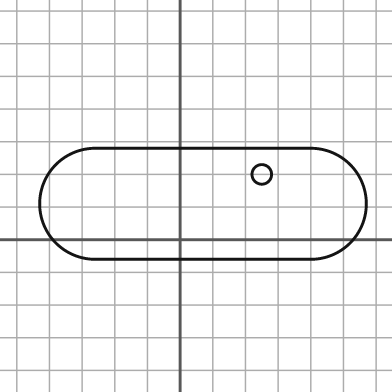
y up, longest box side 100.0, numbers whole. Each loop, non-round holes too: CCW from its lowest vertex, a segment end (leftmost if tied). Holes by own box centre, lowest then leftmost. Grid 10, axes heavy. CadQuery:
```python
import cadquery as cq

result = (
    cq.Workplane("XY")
    .moveTo(-26.0, -6.0)
    .lineTo(40.0, -6.0)
    .threePointArc((57.0, 11.0), (40.0, 28.0))
    .lineTo(-26.0, 28.0)
    .threePointArc((-43.0, 11.0), (-26.0, -6.0))
    .close()
    .moveTo(25.0, 20.0)
    .circle(3.0)
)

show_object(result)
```